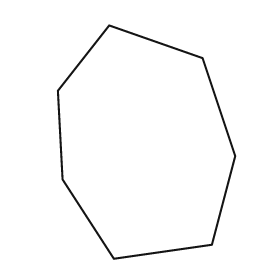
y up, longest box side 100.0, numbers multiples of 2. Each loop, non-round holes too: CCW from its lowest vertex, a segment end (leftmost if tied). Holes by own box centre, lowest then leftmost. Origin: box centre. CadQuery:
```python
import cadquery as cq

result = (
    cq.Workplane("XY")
    .moveTo(-14.0, -50.0)
    .lineTo(28.0, -44.0)
    .lineTo(38.0, -6.0)
    .lineTo(24.0, 36.0)
    .lineTo(-16.0, 50.0)
    .lineTo(-38.0, 22.0)
    .lineTo(-36.0, -16.0)
    .close()
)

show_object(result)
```